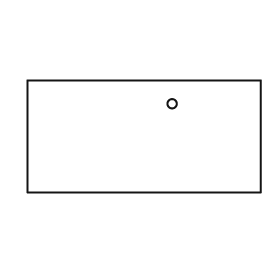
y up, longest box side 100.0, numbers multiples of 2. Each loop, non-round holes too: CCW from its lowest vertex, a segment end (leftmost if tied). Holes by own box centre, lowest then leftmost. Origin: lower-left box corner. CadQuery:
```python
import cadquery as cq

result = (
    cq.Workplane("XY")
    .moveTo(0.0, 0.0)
    .lineTo(100.0, 0.0)
    .lineTo(100.0, 48.0)
    .lineTo(0.0, 48.0)
    .close()
    .moveTo(62.0, 38.0)
    .circle(2.0)
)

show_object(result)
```